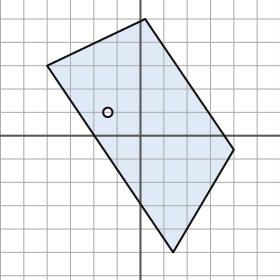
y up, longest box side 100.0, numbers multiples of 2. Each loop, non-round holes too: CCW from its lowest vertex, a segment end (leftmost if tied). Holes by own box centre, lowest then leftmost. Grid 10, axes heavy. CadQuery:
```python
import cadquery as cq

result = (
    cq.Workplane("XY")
    .moveTo(14.0, -50.0)
    .lineTo(40.0, -6.0)
    .lineTo(2.0, 50.0)
    .lineTo(-40.0, 30.0)
    .close()
    .moveTo(-14.0, 10.0)
    .circle(2.0)
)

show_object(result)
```